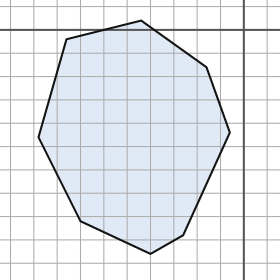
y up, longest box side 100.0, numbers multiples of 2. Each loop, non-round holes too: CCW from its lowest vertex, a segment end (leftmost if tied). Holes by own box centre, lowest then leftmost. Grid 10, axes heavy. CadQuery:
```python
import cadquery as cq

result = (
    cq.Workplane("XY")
    .moveTo(-40.0, -96.0)
    .lineTo(-26.0, -88.0)
    .lineTo(-6.0, -44.0)
    .lineTo(-16.0, -16.0)
    .lineTo(-44.0, 4.0)
    .lineTo(-76.0, -4.0)
    .lineTo(-88.0, -46.0)
    .lineTo(-70.0, -82.0)
    .close()
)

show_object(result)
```